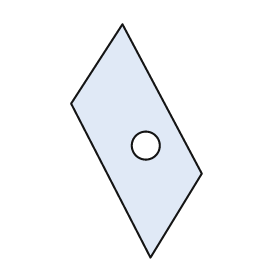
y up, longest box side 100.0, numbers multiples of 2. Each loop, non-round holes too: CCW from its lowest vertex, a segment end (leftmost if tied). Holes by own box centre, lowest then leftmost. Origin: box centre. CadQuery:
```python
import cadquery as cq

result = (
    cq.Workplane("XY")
    .moveTo(6.0, -50.0)
    .lineTo(28.0, -14.0)
    .lineTo(-6.0, 50.0)
    .lineTo(-28.0, 16.0)
    .close()
    .moveTo(4.0, -2.0)
    .circle(6.0)
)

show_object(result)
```